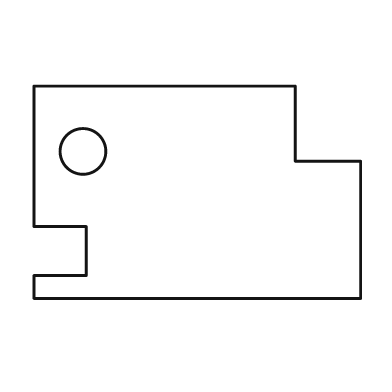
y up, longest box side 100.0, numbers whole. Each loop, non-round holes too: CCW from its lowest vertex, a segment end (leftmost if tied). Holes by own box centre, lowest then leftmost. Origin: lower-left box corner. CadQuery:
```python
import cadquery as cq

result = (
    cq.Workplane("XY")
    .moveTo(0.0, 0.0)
    .lineTo(100.0, 0.0)
    .lineTo(100.0, 42.0)
    .lineTo(80.0, 42.0)
    .lineTo(80.0, 65.0)
    .lineTo(0.0, 65.0)
    .lineTo(0.0, 22.0)
    .lineTo(16.0, 22.0)
    .lineTo(16.0, 7.0)
    .lineTo(0.0, 7.0)
    .close()
    .moveTo(15.0, 45.0)
    .circle(7.0)
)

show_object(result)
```